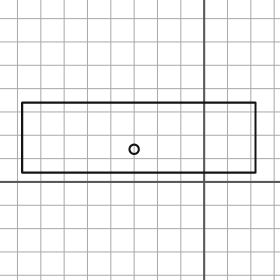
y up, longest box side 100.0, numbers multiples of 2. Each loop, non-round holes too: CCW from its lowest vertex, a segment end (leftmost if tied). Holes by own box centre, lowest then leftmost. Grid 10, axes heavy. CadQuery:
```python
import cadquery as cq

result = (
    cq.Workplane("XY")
    .moveTo(-78.0, 4.0)
    .lineTo(22.0, 4.0)
    .lineTo(22.0, 34.0)
    .lineTo(-78.0, 34.0)
    .close()
    .moveTo(-30.0, 14.0)
    .circle(2.0)
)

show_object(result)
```